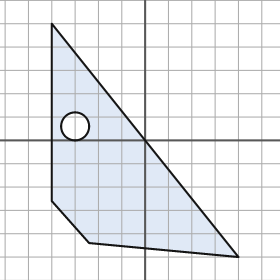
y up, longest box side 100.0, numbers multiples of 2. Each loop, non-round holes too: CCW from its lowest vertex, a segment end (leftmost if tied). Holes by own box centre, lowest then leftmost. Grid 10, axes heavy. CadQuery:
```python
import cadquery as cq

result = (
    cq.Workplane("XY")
    .moveTo(40.0, -50.0)
    .lineTo(-40.0, 50.0)
    .lineTo(-40.0, -26.0)
    .lineTo(-24.0, -44.0)
    .close()
    .moveTo(-30.0, 6.0)
    .circle(6.0)
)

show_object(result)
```